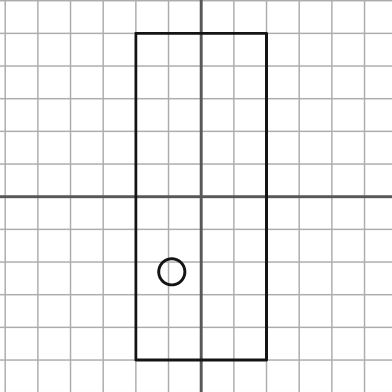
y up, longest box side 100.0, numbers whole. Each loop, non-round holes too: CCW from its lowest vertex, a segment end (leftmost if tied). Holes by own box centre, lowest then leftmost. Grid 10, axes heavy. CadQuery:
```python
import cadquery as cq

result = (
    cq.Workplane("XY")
    .moveTo(-20.0, -50.0)
    .lineTo(20.0, -50.0)
    .lineTo(20.0, 50.0)
    .lineTo(-20.0, 50.0)
    .close()
    .moveTo(-9.0, -23.0)
    .circle(4.0)
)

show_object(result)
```